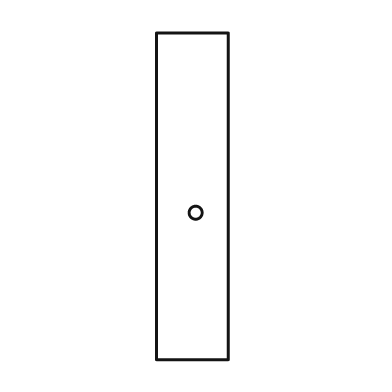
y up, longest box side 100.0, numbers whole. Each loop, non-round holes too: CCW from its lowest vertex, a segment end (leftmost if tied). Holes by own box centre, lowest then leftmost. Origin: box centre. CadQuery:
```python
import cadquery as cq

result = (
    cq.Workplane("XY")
    .moveTo(-11.0, -50.0)
    .lineTo(11.0, -50.0)
    .lineTo(11.0, 50.0)
    .lineTo(-11.0, 50.0)
    .close()
    .moveTo(1.0, -5.0)
    .circle(2.0)
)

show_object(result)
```